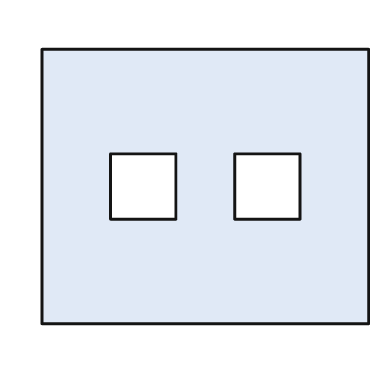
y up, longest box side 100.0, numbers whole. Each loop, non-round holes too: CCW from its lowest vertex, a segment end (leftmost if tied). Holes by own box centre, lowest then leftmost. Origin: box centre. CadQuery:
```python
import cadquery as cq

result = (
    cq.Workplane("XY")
    .moveTo(-50.0, -42.0)
    .lineTo(50.0, -42.0)
    .lineTo(50.0, 42.0)
    .lineTo(-50.0, 42.0)
    .close()
    .moveTo(-29.0, -10.0)
    .lineTo(-9.0, -10.0)
    .lineTo(-9.0, 10.0)
    .lineTo(-29.0, 10.0)
    .close()
    .moveTo(9.0, -10.0)
    .lineTo(29.0, -10.0)
    .lineTo(29.0, 10.0)
    .lineTo(9.0, 10.0)
    .close()
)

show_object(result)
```